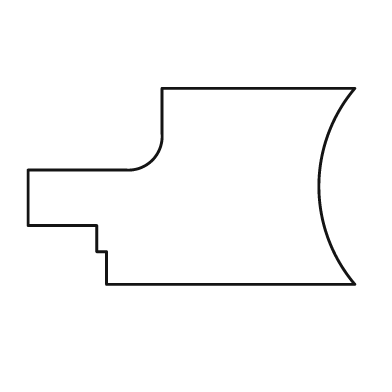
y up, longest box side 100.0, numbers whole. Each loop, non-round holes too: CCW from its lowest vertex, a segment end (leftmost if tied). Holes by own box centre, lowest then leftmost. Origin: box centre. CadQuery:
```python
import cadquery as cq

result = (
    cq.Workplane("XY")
    .moveTo(-26.0, -30.0)
    .lineTo(50.0, -30.0)
    .threePointArc((39.0, 0.0), (50.0, 30.0))
    .lineTo(-9.0, 30.0)
    .lineTo(-9.0, 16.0)
    .threePointArc((-12.0, 8.0), (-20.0, 5.0))
    .lineTo(-50.0, 5.0)
    .lineTo(-50.0, -12.0)
    .lineTo(-29.0, -12.0)
    .lineTo(-29.0, -20.0)
    .lineTo(-26.0, -20.0)
    .close()
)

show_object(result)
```